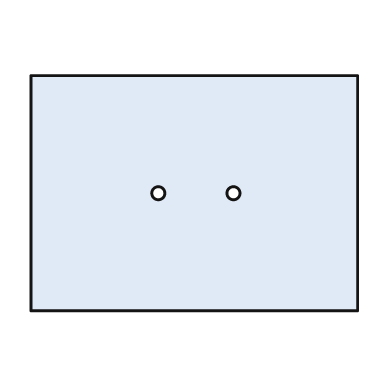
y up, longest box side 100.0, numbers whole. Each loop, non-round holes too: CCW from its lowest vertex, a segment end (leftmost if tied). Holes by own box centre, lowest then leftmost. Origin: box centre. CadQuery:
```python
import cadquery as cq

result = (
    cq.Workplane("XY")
    .moveTo(-50.0, -36.0)
    .lineTo(50.0, -36.0)
    .lineTo(50.0, 36.0)
    .lineTo(-50.0, 36.0)
    .close()
    .moveTo(-11.0, 0.0)
    .circle(2.0)
    .moveTo(12.0, 0.0)
    .circle(2.0)
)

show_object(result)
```